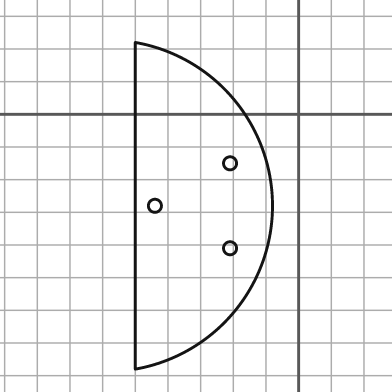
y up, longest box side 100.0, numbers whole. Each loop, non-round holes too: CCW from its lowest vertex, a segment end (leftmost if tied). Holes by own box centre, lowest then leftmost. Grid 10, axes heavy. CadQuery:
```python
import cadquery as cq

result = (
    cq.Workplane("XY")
    .moveTo(-50.0, -78.0)
    .threePointArc((-8.0, -28.0), (-50.0, 22.0))
    .close()
    .moveTo(-21.0, -41.0)
    .circle(2.0)
    .moveTo(-44.0, -28.0)
    .circle(2.0)
    .moveTo(-21.0, -15.0)
    .circle(2.0)
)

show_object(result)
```